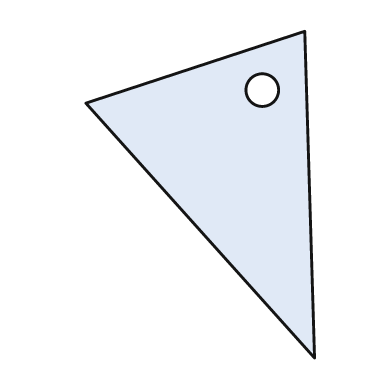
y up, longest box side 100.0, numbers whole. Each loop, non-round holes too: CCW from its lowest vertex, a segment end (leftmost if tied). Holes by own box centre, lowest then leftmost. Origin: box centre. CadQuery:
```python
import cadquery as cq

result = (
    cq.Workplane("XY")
    .moveTo(35.0, -50.0)
    .lineTo(32.0, 50.0)
    .lineTo(-35.0, 28.0)
    .close()
    .moveTo(19.0, 32.0)
    .circle(5.0)
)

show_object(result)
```